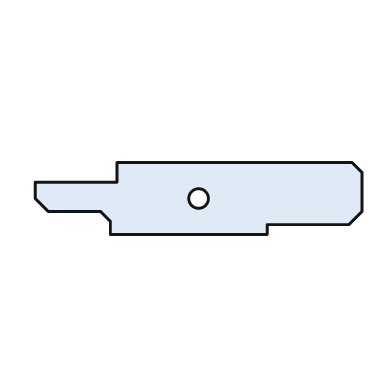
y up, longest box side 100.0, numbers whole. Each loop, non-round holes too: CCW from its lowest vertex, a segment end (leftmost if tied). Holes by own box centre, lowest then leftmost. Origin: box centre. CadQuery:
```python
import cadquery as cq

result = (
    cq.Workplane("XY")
    .moveTo(-27.0, -11.0)
    .lineTo(21.0, -11.0)
    .lineTo(21.0, -8.0)
    .lineTo(46.0, -8.0)
    .lineTo(50.0, -4.0)
    .lineTo(50.0, 8.0)
    .lineTo(47.0, 11.0)
    .lineTo(-25.0, 11.0)
    .lineTo(-25.0, 5.0)
    .lineTo(-50.0, 5.0)
    .lineTo(-50.0, 0.0)
    .lineTo(-46.0, -4.0)
    .lineTo(-30.0, -4.0)
    .lineTo(-27.0, -7.0)
    .close()
    .moveTo(0.0, 0.0)
    .circle(3.0)
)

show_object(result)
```